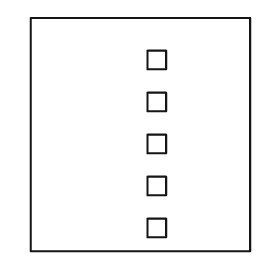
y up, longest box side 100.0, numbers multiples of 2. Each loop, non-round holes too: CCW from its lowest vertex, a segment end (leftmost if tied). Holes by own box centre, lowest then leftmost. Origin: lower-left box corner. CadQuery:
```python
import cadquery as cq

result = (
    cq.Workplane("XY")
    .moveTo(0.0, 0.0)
    .lineTo(94.0, 0.0)
    .lineTo(94.0, 100.0)
    .lineTo(0.0, 100.0)
    .close()
    .moveTo(50.0, 6.0)
    .lineTo(58.0, 6.0)
    .lineTo(58.0, 14.0)
    .lineTo(50.0, 14.0)
    .close()
    .moveTo(50.0, 24.0)
    .lineTo(58.0, 24.0)
    .lineTo(58.0, 32.0)
    .lineTo(50.0, 32.0)
    .close()
    .moveTo(50.0, 42.0)
    .lineTo(58.0, 42.0)
    .lineTo(58.0, 50.0)
    .lineTo(50.0, 50.0)
    .close()
    .moveTo(50.0, 60.0)
    .lineTo(58.0, 60.0)
    .lineTo(58.0, 68.0)
    .lineTo(50.0, 68.0)
    .close()
    .moveTo(50.0, 78.0)
    .lineTo(58.0, 78.0)
    .lineTo(58.0, 86.0)
    .lineTo(50.0, 86.0)
    .close()
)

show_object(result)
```